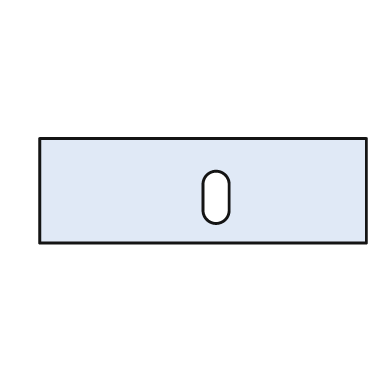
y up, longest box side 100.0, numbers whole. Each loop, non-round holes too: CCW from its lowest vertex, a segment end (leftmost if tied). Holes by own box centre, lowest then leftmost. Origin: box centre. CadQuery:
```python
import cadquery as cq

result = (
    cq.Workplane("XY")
    .moveTo(-50.0, -16.0)
    .lineTo(50.0, -16.0)
    .lineTo(50.0, 16.0)
    .lineTo(-50.0, 16.0)
    .close()
    .moveTo(0.0, -6.0)
    .threePointArc((4.0, -10.0), (8.0, -6.0))
    .lineTo(8.0, 2.0)
    .threePointArc((4.0, 6.0), (0.0, 2.0))
    .close()
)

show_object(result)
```